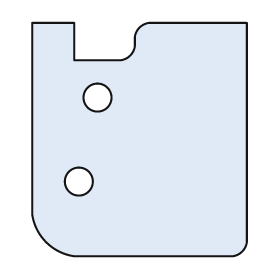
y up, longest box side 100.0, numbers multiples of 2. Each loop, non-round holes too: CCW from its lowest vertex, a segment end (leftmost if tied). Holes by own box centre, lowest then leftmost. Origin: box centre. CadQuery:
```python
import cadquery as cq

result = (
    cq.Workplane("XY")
    .moveTo(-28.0, -50.0)
    .lineTo(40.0, -50.0)
    .threePointArc((44.0, -48.0), (46.0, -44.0))
    .lineTo(46.0, 50.0)
    .lineTo(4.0, 50.0)
    .threePointArc((0.0, 48.0), (-2.0, 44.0))
    .lineTo(-2.0, 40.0)
    .threePointArc((-4.0, 36.0), (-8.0, 34.0))
    .lineTo(-28.0, 34.0)
    .lineTo(-28.0, 50.0)
    .lineTo(-46.0, 50.0)
    .lineTo(-46.0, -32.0)
    .threePointArc((-40.0, -44.0), (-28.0, -50.0))
    .close()
    .moveTo(-26.0, -18.0)
    .circle(6.0)
    .moveTo(-18.0, 18.0)
    .circle(6.0)
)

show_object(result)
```